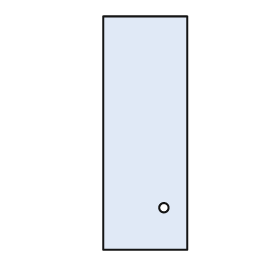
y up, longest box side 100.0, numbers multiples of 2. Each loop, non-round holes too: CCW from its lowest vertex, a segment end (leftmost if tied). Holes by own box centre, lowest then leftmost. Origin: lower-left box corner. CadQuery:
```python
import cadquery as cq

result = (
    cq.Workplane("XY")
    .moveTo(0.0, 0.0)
    .lineTo(36.0, 0.0)
    .lineTo(36.0, 100.0)
    .lineTo(0.0, 100.0)
    .close()
    .moveTo(26.0, 18.0)
    .circle(2.0)
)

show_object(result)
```